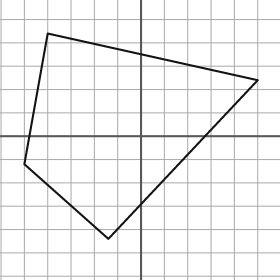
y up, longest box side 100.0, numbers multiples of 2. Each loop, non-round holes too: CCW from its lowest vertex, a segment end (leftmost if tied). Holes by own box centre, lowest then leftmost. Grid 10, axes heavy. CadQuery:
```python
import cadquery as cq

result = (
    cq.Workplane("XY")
    .moveTo(-14.0, -44.0)
    .lineTo(50.0, 24.0)
    .lineTo(-40.0, 44.0)
    .lineTo(-50.0, -12.0)
    .close()
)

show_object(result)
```